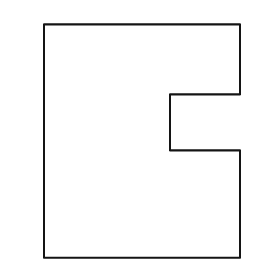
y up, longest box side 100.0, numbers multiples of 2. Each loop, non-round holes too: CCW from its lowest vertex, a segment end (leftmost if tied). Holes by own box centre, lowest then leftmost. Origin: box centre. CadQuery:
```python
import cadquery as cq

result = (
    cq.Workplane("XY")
    .moveTo(-42.0, -50.0)
    .lineTo(42.0, -50.0)
    .lineTo(42.0, -4.0)
    .lineTo(12.0, -4.0)
    .lineTo(12.0, 20.0)
    .lineTo(42.0, 20.0)
    .lineTo(42.0, 50.0)
    .lineTo(-42.0, 50.0)
    .close()
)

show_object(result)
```